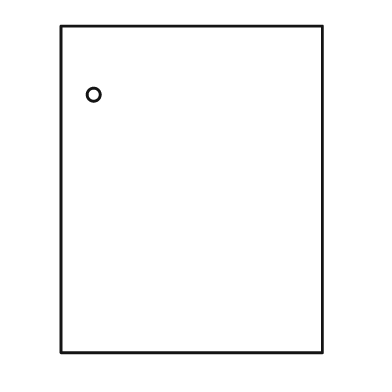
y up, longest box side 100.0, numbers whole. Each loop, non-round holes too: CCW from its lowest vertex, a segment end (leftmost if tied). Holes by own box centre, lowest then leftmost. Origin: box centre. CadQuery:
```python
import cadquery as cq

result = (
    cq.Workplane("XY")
    .moveTo(-40.0, -50.0)
    .lineTo(40.0, -50.0)
    .lineTo(40.0, 50.0)
    .lineTo(-40.0, 50.0)
    .close()
    .moveTo(-30.0, 29.0)
    .circle(2.0)
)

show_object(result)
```